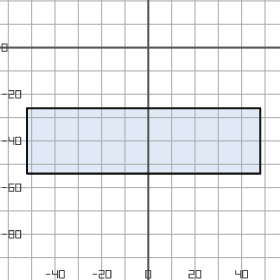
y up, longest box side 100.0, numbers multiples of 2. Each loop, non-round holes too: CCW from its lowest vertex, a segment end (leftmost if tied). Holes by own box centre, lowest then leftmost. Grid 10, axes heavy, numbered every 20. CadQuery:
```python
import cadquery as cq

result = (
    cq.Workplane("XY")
    .moveTo(-52.0, -54.0)
    .lineTo(48.0, -54.0)
    .lineTo(48.0, -26.0)
    .lineTo(-52.0, -26.0)
    .close()
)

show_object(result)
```